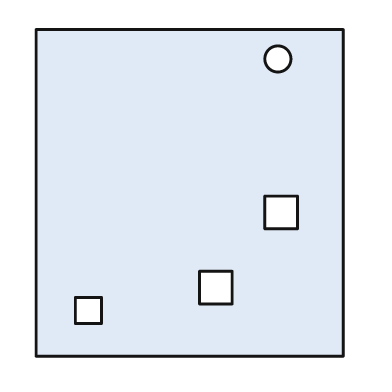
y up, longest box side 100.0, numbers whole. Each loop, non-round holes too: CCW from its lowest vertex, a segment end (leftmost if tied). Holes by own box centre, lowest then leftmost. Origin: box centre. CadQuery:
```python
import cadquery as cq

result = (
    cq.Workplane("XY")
    .moveTo(-47.0, -50.0)
    .lineTo(47.0, -50.0)
    .lineTo(47.0, 50.0)
    .lineTo(-47.0, 50.0)
    .close()
    .moveTo(-35.0, -40.0)
    .lineTo(-27.0, -40.0)
    .lineTo(-27.0, -32.0)
    .lineTo(-35.0, -32.0)
    .close()
    .moveTo(3.0, -34.0)
    .lineTo(13.0, -34.0)
    .lineTo(13.0, -24.0)
    .lineTo(3.0, -24.0)
    .close()
    .moveTo(23.0, -11.0)
    .lineTo(33.0, -11.0)
    .lineTo(33.0, -1.0)
    .lineTo(23.0, -1.0)
    .close()
    .moveTo(27.0, 41.0)
    .circle(4.0)
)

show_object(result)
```